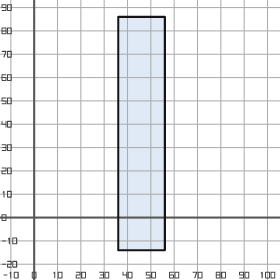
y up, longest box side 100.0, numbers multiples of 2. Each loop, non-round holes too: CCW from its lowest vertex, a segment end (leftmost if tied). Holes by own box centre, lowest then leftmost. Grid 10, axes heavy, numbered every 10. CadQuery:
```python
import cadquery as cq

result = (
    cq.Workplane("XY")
    .moveTo(36.0, -14.0)
    .lineTo(56.0, -14.0)
    .lineTo(56.0, 86.0)
    .lineTo(36.0, 86.0)
    .close()
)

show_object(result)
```